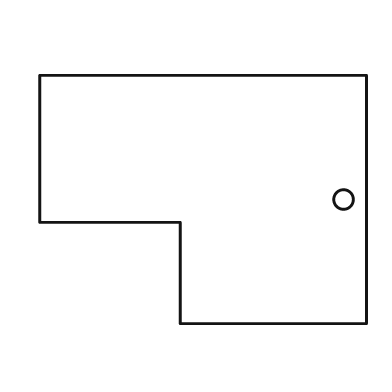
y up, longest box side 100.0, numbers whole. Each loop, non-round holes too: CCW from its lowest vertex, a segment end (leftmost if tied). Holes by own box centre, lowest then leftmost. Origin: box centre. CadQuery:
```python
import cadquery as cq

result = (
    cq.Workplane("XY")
    .moveTo(-7.0, -38.0)
    .lineTo(50.0, -38.0)
    .lineTo(50.0, 38.0)
    .lineTo(-50.0, 38.0)
    .lineTo(-50.0, -7.0)
    .lineTo(-7.0, -7.0)
    .close()
    .moveTo(43.0, 0.0)
    .circle(3.0)
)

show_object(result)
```